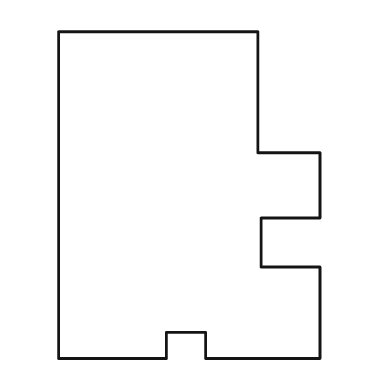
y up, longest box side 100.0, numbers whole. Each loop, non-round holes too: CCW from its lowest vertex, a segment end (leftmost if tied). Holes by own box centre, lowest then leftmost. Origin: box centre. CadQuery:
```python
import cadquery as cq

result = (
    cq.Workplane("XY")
    .moveTo(-40.0, -50.0)
    .lineTo(-7.0, -50.0)
    .lineTo(-7.0, -42.0)
    .lineTo(5.0, -42.0)
    .lineTo(5.0, -50.0)
    .lineTo(40.0, -50.0)
    .lineTo(40.0, -22.0)
    .lineTo(22.0, -22.0)
    .lineTo(22.0, -7.0)
    .lineTo(40.0, -7.0)
    .lineTo(40.0, 13.0)
    .lineTo(21.0, 13.0)
    .lineTo(21.0, 50.0)
    .lineTo(-40.0, 50.0)
    .close()
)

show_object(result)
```